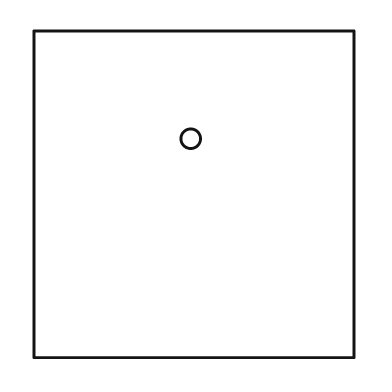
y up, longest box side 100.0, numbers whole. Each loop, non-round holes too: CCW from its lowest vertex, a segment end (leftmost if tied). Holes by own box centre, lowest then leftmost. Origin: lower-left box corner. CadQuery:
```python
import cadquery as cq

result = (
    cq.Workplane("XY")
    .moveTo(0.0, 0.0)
    .lineTo(98.0, 0.0)
    .lineTo(98.0, 100.0)
    .lineTo(0.0, 100.0)
    .close()
    .moveTo(48.0, 67.0)
    .circle(3.0)
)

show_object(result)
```